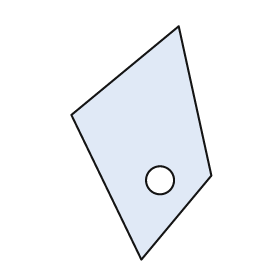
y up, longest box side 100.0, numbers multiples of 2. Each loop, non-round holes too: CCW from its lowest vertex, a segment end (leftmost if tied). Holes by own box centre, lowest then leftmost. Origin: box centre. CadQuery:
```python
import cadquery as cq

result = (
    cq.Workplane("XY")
    .moveTo(0.0, -50.0)
    .lineTo(30.0, -14.0)
    .lineTo(16.0, 50.0)
    .lineTo(-30.0, 12.0)
    .close()
    .moveTo(8.0, -16.0)
    .circle(6.0)
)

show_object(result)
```